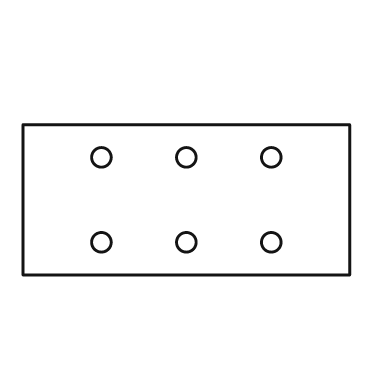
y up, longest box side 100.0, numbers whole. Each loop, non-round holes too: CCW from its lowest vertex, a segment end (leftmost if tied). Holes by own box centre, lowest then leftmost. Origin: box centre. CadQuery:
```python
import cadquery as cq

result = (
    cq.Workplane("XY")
    .moveTo(-50.0, -23.0)
    .lineTo(50.0, -23.0)
    .lineTo(50.0, 23.0)
    .lineTo(-50.0, 23.0)
    .close()
    .moveTo(-26.0, -13.0)
    .circle(3.0)
    .moveTo(0.0, -13.0)
    .circle(3.0)
    .moveTo(26.0, -13.0)
    .circle(3.0)
    .moveTo(-26.0, 13.0)
    .circle(3.0)
    .moveTo(0.0, 13.0)
    .circle(3.0)
    .moveTo(26.0, 13.0)
    .circle(3.0)
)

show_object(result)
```